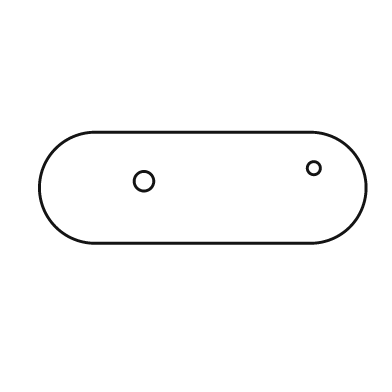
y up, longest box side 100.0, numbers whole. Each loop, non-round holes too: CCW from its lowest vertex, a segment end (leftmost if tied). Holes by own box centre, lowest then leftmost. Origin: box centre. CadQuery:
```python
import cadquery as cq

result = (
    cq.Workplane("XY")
    .moveTo(-33.0, -17.0)
    .lineTo(33.0, -17.0)
    .threePointArc((50.0, 0.0), (33.0, 17.0))
    .lineTo(-33.0, 17.0)
    .threePointArc((-50.0, 0.0), (-33.0, -17.0))
    .close()
    .moveTo(-18.0, 2.0)
    .circle(3.0)
    .moveTo(34.0, 6.0)
    .circle(2.0)
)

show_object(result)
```